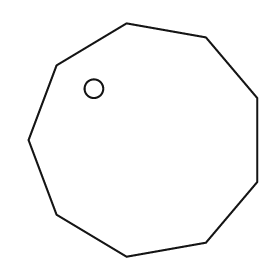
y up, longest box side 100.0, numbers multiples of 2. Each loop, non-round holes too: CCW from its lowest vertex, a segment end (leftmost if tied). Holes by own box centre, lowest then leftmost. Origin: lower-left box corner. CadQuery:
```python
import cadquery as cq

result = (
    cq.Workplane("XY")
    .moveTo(42.0, 0.0)
    .lineTo(76.0, 6.0)
    .lineTo(98.0, 32.0)
    .lineTo(98.0, 68.0)
    .lineTo(76.0, 94.0)
    .lineTo(42.0, 100.0)
    .lineTo(12.0, 82.0)
    .lineTo(0.0, 50.0)
    .lineTo(12.0, 18.0)
    .close()
    .moveTo(28.0, 72.0)
    .circle(4.0)
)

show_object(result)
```